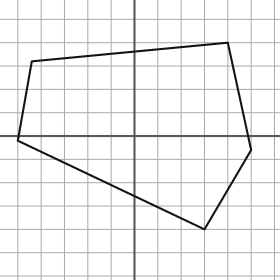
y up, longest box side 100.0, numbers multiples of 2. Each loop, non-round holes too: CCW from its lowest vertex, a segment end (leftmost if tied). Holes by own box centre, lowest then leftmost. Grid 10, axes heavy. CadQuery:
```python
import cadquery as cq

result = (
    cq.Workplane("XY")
    .moveTo(30.0, -40.0)
    .lineTo(50.0, -6.0)
    .lineTo(40.0, 40.0)
    .lineTo(-44.0, 32.0)
    .lineTo(-50.0, -2.0)
    .close()
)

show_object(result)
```